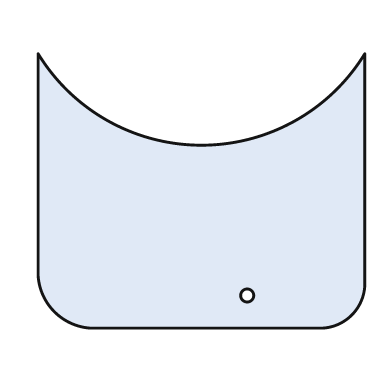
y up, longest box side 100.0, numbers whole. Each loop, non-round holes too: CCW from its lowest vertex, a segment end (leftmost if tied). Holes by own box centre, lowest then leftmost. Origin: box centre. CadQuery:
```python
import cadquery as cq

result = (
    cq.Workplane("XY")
    .moveTo(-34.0, -42.0)
    .lineTo(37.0, -42.0)
    .threePointArc((46.0, -38.0), (50.0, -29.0))
    .lineTo(50.0, 42.0)
    .threePointArc((0.0, 14.0), (-50.0, 42.0))
    .lineTo(-50.0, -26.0)
    .threePointArc((-45.0, -37.0), (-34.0, -42.0))
    .close()
    .moveTo(14.0, -32.0)
    .circle(2.0)
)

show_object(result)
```